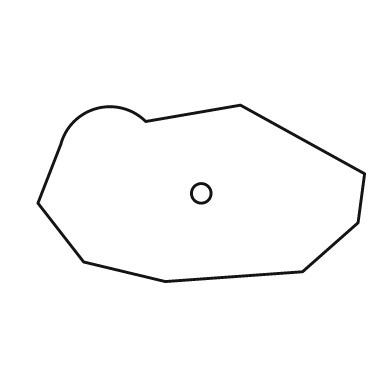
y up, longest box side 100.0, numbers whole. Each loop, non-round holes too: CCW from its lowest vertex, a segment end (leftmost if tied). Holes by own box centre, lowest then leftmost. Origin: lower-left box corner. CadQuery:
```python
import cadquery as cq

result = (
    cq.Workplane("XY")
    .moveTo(39.0, 0.0)
    .lineTo(81.0, 3.0)
    .lineTo(98.0, 18.0)
    .lineTo(100.0, 33.0)
    .lineTo(62.0, 54.0)
    .lineTo(33.0, 49.0)
    .threePointArc((18.0, 53.0), (7.0, 42.0))
    .lineTo(0.0, 24.0)
    .lineTo(14.0, 6.0)
    .close()
    .moveTo(50.0, 27.0)
    .circle(3.0)
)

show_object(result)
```